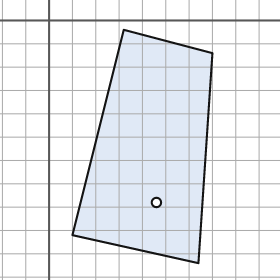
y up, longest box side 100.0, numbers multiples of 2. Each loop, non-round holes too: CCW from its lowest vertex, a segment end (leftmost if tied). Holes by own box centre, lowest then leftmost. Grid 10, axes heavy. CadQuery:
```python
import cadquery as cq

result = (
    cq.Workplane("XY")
    .moveTo(64.0, -104.0)
    .lineTo(70.0, -14.0)
    .lineTo(32.0, -4.0)
    .lineTo(10.0, -92.0)
    .close()
    .moveTo(46.0, -78.0)
    .circle(2.0)
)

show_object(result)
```